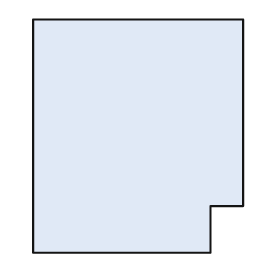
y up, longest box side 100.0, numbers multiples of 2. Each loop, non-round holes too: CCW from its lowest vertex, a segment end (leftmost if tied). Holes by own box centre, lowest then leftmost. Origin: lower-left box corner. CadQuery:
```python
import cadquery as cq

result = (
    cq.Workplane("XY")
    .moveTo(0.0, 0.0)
    .lineTo(76.0, 0.0)
    .lineTo(76.0, 20.0)
    .lineTo(90.0, 20.0)
    .lineTo(90.0, 100.0)
    .lineTo(0.0, 100.0)
    .close()
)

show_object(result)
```